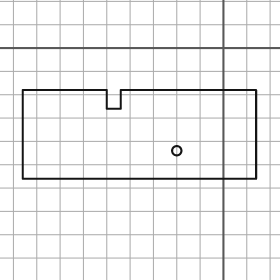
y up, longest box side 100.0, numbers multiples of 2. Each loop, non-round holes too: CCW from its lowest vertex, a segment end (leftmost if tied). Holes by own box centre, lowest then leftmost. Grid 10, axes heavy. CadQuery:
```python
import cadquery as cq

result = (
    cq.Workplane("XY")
    .moveTo(-86.0, -56.0)
    .lineTo(14.0, -56.0)
    .lineTo(14.0, -18.0)
    .lineTo(-44.0, -18.0)
    .lineTo(-44.0, -26.0)
    .lineTo(-50.0, -26.0)
    .lineTo(-50.0, -18.0)
    .lineTo(-86.0, -18.0)
    .close()
    .moveTo(-20.0, -44.0)
    .circle(2.0)
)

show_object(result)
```